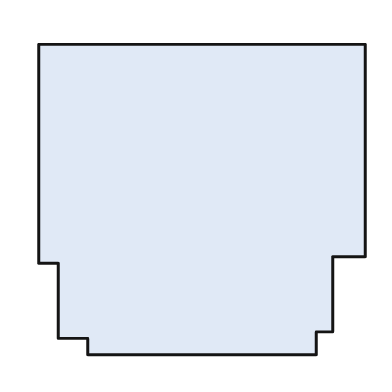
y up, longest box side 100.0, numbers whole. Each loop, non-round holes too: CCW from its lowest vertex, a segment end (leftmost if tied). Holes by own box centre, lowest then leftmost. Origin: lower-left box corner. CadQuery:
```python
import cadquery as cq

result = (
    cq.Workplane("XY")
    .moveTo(15.0, 0.0)
    .lineTo(85.0, 0.0)
    .lineTo(85.0, 7.0)
    .lineTo(90.0, 7.0)
    .lineTo(90.0, 30.0)
    .lineTo(100.0, 30.0)
    .lineTo(100.0, 95.0)
    .lineTo(0.0, 95.0)
    .lineTo(0.0, 28.0)
    .lineTo(6.0, 28.0)
    .lineTo(6.0, 5.0)
    .lineTo(15.0, 5.0)
    .close()
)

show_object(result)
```